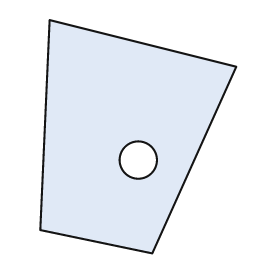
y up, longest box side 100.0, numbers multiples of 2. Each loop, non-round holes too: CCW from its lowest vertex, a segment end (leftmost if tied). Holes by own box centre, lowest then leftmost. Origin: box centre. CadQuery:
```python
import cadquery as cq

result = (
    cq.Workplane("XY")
    .moveTo(6.0, -50.0)
    .lineTo(42.0, 30.0)
    .lineTo(-38.0, 50.0)
    .lineTo(-42.0, -40.0)
    .close()
    .moveTo(0.0, -10.0)
    .circle(8.0)
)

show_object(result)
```